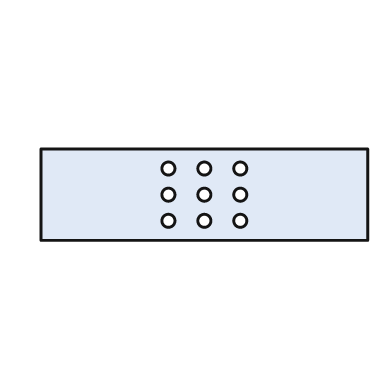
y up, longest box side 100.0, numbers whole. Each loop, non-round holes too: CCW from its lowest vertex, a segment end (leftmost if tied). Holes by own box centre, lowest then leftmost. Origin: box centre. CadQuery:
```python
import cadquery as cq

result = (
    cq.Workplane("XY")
    .moveTo(-50.0, -14.0)
    .lineTo(50.0, -14.0)
    .lineTo(50.0, 14.0)
    .lineTo(-50.0, 14.0)
    .close()
    .moveTo(-11.0, -8.0)
    .circle(2.0)
    .moveTo(0.0, -8.0)
    .circle(2.0)
    .moveTo(11.0, -8.0)
    .circle(2.0)
    .moveTo(-11.0, 0.0)
    .circle(2.0)
    .moveTo(0.0, 0.0)
    .circle(2.0)
    .moveTo(11.0, 0.0)
    .circle(2.0)
    .moveTo(-11.0, 8.0)
    .circle(2.0)
    .moveTo(0.0, 8.0)
    .circle(2.0)
    .moveTo(11.0, 8.0)
    .circle(2.0)
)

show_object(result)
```